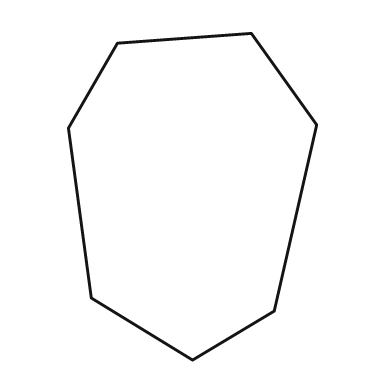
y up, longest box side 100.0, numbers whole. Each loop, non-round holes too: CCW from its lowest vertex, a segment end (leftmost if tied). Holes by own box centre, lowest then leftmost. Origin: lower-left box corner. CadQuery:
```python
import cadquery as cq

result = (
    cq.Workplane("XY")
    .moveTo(38.0, 0.0)
    .lineTo(63.0, 15.0)
    .lineTo(76.0, 72.0)
    .lineTo(56.0, 100.0)
    .lineTo(15.0, 97.0)
    .lineTo(0.0, 71.0)
    .lineTo(7.0, 19.0)
    .close()
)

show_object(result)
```